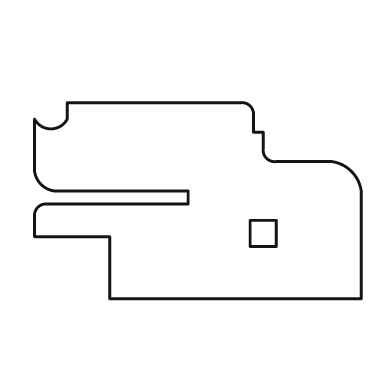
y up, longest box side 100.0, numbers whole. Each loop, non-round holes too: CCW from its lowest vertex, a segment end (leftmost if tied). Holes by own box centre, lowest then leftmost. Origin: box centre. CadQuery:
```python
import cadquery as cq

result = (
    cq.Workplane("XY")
    .moveTo(-27.0, -30.0)
    .lineTo(50.0, -30.0)
    .lineTo(50.0, 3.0)
    .threePointArc((47.0, 9.0), (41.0, 12.0))
    .lineTo(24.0, 12.0)
    .threePointArc((21.0, 13.0), (20.0, 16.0))
    .lineTo(20.0, 21.0)
    .lineTo(17.0, 21.0)
    .lineTo(17.0, 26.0)
    .threePointArc((16.0, 29.0), (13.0, 30.0))
    .lineTo(-40.0, 30.0)
    .lineTo(-40.0, 25.0)
    .threePointArc((-45.0, 22.0), (-50.0, 25.0))
    .lineTo(-50.0, 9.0)
    .threePointArc((-48.0, 5.0), (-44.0, 3.0))
    .lineTo(-3.0, 3.0)
    .lineTo(-3.0, -1.0)
    .lineTo(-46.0, -1.0)
    .threePointArc((-49.0, -2.0), (-50.0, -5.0))
    .lineTo(-50.0, -11.0)
    .lineTo(-27.0, -11.0)
    .close()
    .moveTo(16.0, -14.0)
    .lineTo(24.0, -14.0)
    .lineTo(24.0, -6.0)
    .lineTo(16.0, -6.0)
    .close()
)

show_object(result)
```